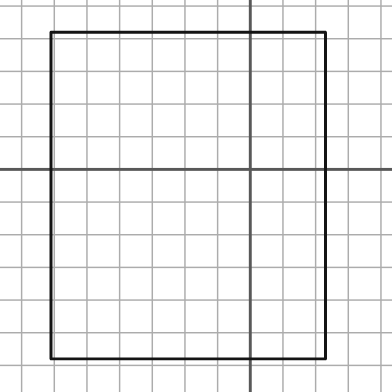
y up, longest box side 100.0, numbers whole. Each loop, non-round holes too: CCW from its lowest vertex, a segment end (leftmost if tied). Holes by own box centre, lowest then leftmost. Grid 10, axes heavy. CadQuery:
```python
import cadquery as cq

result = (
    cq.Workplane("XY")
    .moveTo(-61.0, -58.0)
    .lineTo(23.0, -58.0)
    .lineTo(23.0, 42.0)
    .lineTo(-61.0, 42.0)
    .close()
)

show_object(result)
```